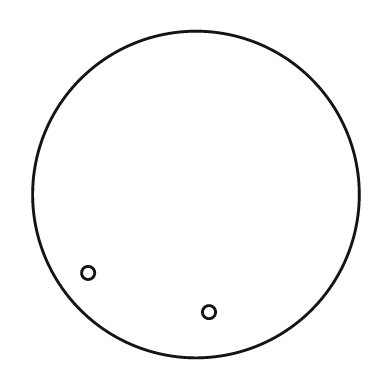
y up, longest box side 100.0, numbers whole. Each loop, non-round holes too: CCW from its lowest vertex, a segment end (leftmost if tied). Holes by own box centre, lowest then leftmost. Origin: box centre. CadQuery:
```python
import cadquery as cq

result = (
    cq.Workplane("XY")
    .moveTo(0.0, 0.0)
    .circle(50.0)
    .moveTo(4.0, -36.0)
    .circle(2.0)
    .moveTo(-33.0, -24.0)
    .circle(2.0)
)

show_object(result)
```